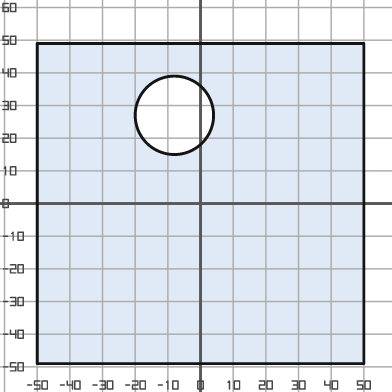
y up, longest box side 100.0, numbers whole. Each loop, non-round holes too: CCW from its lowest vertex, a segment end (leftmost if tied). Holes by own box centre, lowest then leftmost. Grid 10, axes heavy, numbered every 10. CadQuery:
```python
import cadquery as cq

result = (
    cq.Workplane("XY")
    .moveTo(-50.0, -49.0)
    .lineTo(50.0, -49.0)
    .lineTo(50.0, 49.0)
    .lineTo(-50.0, 49.0)
    .close()
    .moveTo(-8.0, 27.0)
    .circle(12.0)
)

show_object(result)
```